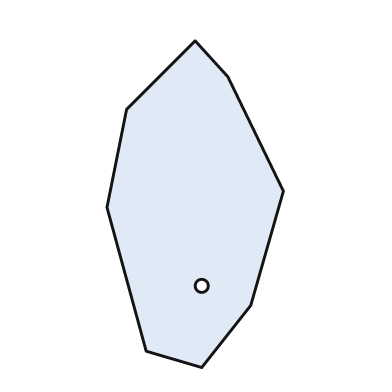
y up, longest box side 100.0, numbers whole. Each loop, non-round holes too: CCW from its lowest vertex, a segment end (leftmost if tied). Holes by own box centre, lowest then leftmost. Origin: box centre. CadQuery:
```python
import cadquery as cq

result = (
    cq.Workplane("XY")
    .moveTo(2.0, -50.0)
    .lineTo(17.0, -31.0)
    .lineTo(27.0, 4.0)
    .lineTo(10.0, 39.0)
    .lineTo(0.0, 50.0)
    .lineTo(-21.0, 29.0)
    .lineTo(-27.0, -1.0)
    .lineTo(-15.0, -45.0)
    .close()
    .moveTo(2.0, -25.0)
    .circle(2.0)
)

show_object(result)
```